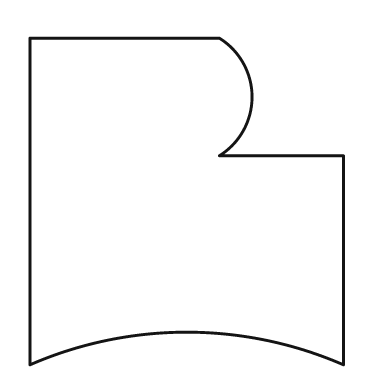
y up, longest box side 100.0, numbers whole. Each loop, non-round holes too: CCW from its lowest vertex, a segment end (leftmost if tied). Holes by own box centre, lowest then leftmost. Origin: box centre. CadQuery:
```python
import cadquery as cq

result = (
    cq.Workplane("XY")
    .moveTo(-48.0, -50.0)
    .threePointArc((0.0, -40.0), (48.0, -50.0))
    .lineTo(48.0, 14.0)
    .lineTo(10.0, 14.0)
    .threePointArc((20.0, 32.0), (10.0, 50.0))
    .lineTo(-48.0, 50.0)
    .close()
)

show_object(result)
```